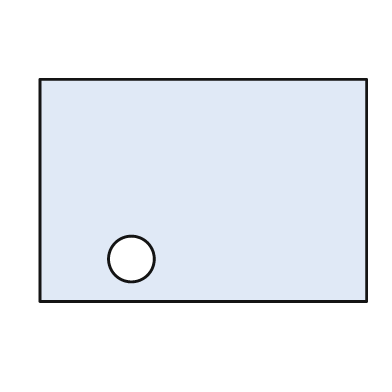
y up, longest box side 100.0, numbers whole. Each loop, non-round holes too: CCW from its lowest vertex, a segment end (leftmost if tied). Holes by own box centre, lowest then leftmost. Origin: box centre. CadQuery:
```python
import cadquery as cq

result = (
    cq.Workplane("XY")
    .moveTo(-50.0, -34.0)
    .lineTo(50.0, -34.0)
    .lineTo(50.0, 34.0)
    .lineTo(-50.0, 34.0)
    .close()
    .moveTo(-22.0, -21.0)
    .circle(7.0)
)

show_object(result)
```